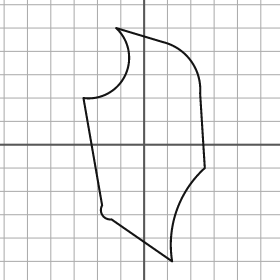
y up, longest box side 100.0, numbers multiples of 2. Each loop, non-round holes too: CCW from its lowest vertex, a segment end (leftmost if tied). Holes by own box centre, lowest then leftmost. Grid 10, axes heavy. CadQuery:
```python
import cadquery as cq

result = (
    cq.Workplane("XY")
    .moveTo(12.0, -50.0)
    .threePointArc((14.0, -28.0), (26.0, -10.0))
    .lineTo(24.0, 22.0)
    .threePointArc((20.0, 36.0), (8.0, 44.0))
    .lineTo(-12.0, 50.0)
    .threePointArc((-8.0, 30.0), (-26.0, 20.0))
    .lineTo(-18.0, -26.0)
    .threePointArc((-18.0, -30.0), (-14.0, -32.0))
    .close()
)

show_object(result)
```